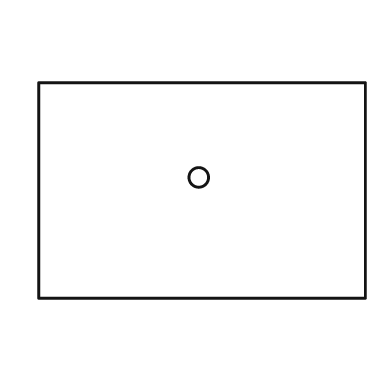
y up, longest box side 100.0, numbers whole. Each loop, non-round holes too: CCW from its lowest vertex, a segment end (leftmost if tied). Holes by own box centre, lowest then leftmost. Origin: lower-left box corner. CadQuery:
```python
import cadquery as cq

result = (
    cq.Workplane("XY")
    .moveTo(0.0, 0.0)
    .lineTo(100.0, 0.0)
    .lineTo(100.0, 66.0)
    .lineTo(0.0, 66.0)
    .close()
    .moveTo(49.0, 37.0)
    .circle(3.0)
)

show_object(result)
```